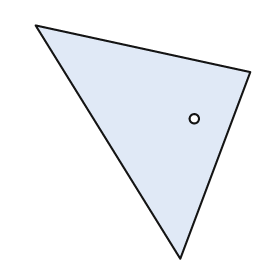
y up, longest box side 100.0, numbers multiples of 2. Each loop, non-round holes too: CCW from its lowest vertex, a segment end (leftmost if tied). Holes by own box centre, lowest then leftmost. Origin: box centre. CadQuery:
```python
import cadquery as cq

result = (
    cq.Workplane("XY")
    .moveTo(16.0, -50.0)
    .lineTo(46.0, 30.0)
    .lineTo(-46.0, 50.0)
    .close()
    .moveTo(22.0, 10.0)
    .circle(2.0)
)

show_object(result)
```